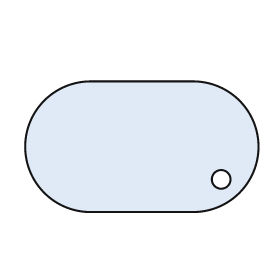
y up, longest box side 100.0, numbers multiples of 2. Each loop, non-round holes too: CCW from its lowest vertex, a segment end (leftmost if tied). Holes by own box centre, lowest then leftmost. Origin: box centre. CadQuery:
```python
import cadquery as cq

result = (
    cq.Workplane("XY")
    .moveTo(-22.0, -28.0)
    .lineTo(22.0, -28.0)
    .threePointArc((50.0, 0.0), (22.0, 28.0))
    .lineTo(-22.0, 28.0)
    .threePointArc((-50.0, 0.0), (-22.0, -28.0))
    .close()
    .moveTo(34.0, -14.0)
    .circle(4.0)
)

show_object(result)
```